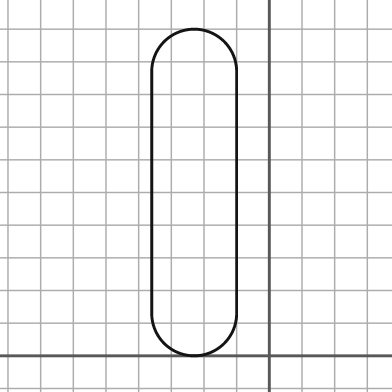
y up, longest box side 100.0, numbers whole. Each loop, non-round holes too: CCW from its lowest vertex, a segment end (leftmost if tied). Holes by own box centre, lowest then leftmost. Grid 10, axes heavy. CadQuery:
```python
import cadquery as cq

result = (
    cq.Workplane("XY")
    .moveTo(-36.0, 13.0)
    .threePointArc((-23.0, 0.0), (-10.0, 13.0))
    .lineTo(-10.0, 87.0)
    .threePointArc((-23.0, 100.0), (-36.0, 87.0))
    .close()
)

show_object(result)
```